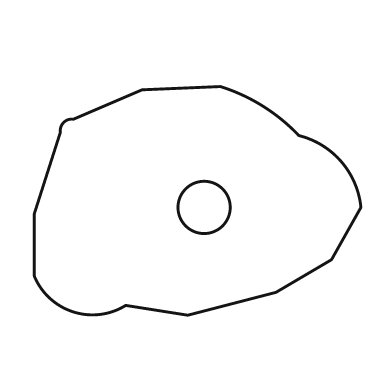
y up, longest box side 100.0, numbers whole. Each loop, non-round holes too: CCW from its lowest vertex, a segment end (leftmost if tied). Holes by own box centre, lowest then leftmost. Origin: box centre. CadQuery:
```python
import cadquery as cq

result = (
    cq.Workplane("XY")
    .moveTo(-3.0, -35.0)
    .lineTo(24.0, -28.0)
    .lineTo(41.0, -18.0)
    .lineTo(50.0, -2.0)
    .threePointArc((44.0, 12.0), (31.0, 20.0))
    .threePointArc((20.0, 29.0), (7.0, 35.0))
    .lineTo(-17.0, 34.0)
    .lineTo(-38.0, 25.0)
    .threePointArc((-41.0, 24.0), (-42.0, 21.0))
    .lineTo(-50.0, -4.0)
    .lineTo(-50.0, -23.0)
    .threePointArc((-38.0, -34.0), (-22.0, -32.0))
    .close()
    .moveTo(2.0, -2.0)
    .circle(8.0)
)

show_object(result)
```